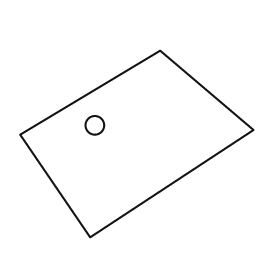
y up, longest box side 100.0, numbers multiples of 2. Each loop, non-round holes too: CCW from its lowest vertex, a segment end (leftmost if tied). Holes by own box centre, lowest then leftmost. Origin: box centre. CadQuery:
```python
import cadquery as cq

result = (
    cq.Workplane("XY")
    .moveTo(-20.0, -40.0)
    .lineTo(50.0, 6.0)
    .lineTo(10.0, 40.0)
    .lineTo(-50.0, 4.0)
    .close()
    .moveTo(-18.0, 8.0)
    .circle(4.0)
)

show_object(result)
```